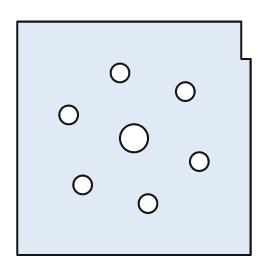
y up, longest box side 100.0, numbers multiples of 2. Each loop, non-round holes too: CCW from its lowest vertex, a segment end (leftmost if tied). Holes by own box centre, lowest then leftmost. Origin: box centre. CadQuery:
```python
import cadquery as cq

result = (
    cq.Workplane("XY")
    .moveTo(-50.0, -50.0)
    .lineTo(50.0, -50.0)
    .lineTo(50.0, 34.0)
    .lineTo(46.0, 34.0)
    .lineTo(46.0, 50.0)
    .lineTo(-50.0, 50.0)
    .close()
    .moveTo(6.0, -28.0)
    .circle(4.0)
    .moveTo(-22.0, -20.0)
    .circle(4.0)
    .moveTo(28.0, -10.0)
    .circle(4.0)
    .moveTo(0.0, 0.0)
    .circle(6.0)
    .moveTo(-28.0, 10.0)
    .circle(4.0)
    .moveTo(22.0, 20.0)
    .circle(4.0)
    .moveTo(-6.0, 28.0)
    .circle(4.0)
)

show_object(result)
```